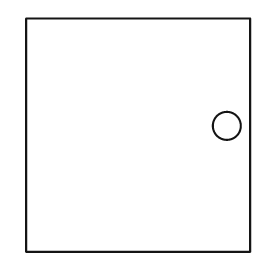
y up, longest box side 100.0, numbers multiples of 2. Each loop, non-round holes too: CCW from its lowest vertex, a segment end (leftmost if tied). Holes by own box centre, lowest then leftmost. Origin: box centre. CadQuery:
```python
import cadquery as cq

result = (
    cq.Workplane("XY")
    .moveTo(-48.0, -50.0)
    .lineTo(48.0, -50.0)
    .lineTo(48.0, 50.0)
    .lineTo(-48.0, 50.0)
    .close()
    .moveTo(38.0, 4.0)
    .circle(6.0)
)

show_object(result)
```